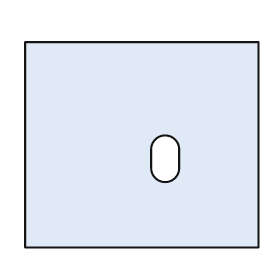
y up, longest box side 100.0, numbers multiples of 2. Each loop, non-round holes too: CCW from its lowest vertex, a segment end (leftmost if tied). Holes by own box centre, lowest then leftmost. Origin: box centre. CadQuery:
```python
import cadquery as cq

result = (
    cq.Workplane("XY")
    .moveTo(-50.0, -44.0)
    .lineTo(50.0, -44.0)
    .lineTo(50.0, 44.0)
    .lineTo(-50.0, 44.0)
    .close()
    .moveTo(4.0, -10.0)
    .threePointArc((10.0, -16.0), (16.0, -10.0))
    .lineTo(16.0, -2.0)
    .threePointArc((10.0, 4.0), (4.0, -2.0))
    .close()
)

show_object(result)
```